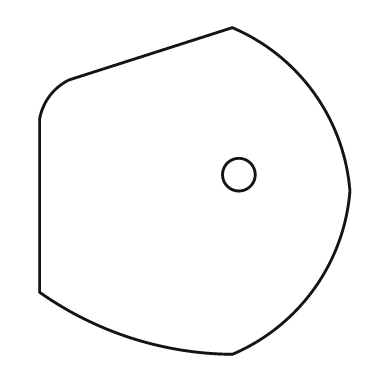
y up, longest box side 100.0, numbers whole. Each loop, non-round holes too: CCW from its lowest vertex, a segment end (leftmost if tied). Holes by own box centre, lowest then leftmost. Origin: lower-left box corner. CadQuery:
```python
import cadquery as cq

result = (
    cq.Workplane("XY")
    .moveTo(59.0, 0.0)
    .threePointArc((84.0, 20.0), (95.0, 50.0))
    .threePointArc((84.0, 80.0), (59.0, 100.0))
    .lineTo(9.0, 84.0)
    .threePointArc((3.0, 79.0), (0.0, 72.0))
    .lineTo(0.0, 19.0)
    .threePointArc((28.0, 5.0), (59.0, 0.0))
    .close()
    .moveTo(61.0, 55.0)
    .circle(5.0)
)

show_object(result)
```